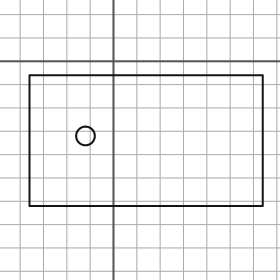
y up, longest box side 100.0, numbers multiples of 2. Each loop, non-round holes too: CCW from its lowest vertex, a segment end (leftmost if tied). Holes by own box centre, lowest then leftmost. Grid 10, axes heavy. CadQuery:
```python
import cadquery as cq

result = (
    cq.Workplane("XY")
    .moveTo(-36.0, -62.0)
    .lineTo(64.0, -62.0)
    .lineTo(64.0, -6.0)
    .lineTo(-36.0, -6.0)
    .close()
    .moveTo(-12.0, -32.0)
    .circle(4.0)
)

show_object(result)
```